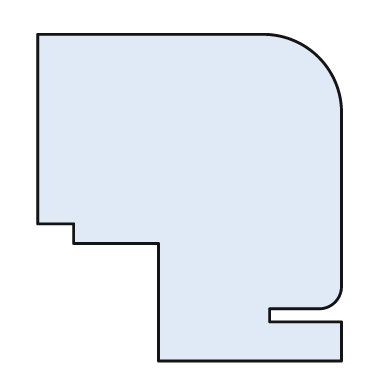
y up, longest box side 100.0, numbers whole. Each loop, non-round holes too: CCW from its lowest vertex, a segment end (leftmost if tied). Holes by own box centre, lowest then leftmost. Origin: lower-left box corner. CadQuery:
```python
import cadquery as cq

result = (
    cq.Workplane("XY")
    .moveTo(37.0, 0.0)
    .lineTo(93.0, 0.0)
    .lineTo(93.0, 12.0)
    .lineTo(71.0, 12.0)
    .lineTo(71.0, 16.0)
    .lineTo(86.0, 16.0)
    .threePointArc((91.0, 18.0), (93.0, 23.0))
    .lineTo(93.0, 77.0)
    .threePointArc((86.0, 93.0), (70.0, 100.0))
    .lineTo(0.0, 100.0)
    .lineTo(0.0, 42.0)
    .lineTo(11.0, 42.0)
    .lineTo(11.0, 36.0)
    .lineTo(37.0, 36.0)
    .close()
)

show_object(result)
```